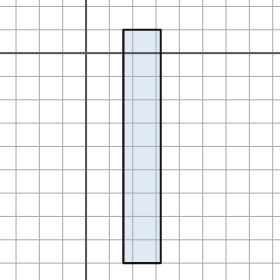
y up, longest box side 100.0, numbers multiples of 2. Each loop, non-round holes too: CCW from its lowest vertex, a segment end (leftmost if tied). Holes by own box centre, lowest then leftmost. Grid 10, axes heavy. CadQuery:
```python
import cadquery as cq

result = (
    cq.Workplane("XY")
    .moveTo(16.0, -90.0)
    .lineTo(32.0, -90.0)
    .lineTo(32.0, 10.0)
    .lineTo(16.0, 10.0)
    .close()
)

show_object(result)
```